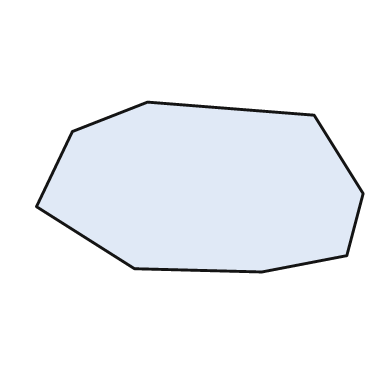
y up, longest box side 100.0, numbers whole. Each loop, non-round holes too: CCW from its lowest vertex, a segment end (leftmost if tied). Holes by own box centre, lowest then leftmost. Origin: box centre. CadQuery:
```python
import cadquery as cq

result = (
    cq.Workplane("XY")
    .moveTo(19.0, -26.0)
    .lineTo(45.0, -21.0)
    .lineTo(50.0, -2.0)
    .lineTo(35.0, 22.0)
    .lineTo(-16.0, 26.0)
    .lineTo(-39.0, 17.0)
    .lineTo(-50.0, -6.0)
    .lineTo(-20.0, -25.0)
    .close()
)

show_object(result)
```